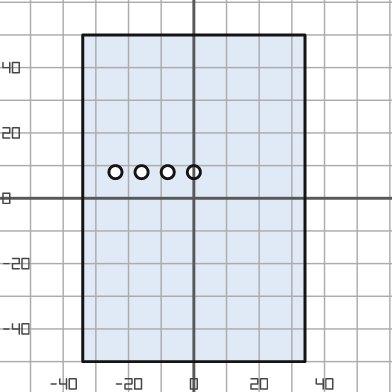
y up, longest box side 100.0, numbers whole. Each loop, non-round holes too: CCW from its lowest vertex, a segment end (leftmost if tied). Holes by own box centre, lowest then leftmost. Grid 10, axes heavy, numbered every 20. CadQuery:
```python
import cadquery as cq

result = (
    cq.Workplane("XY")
    .moveTo(-34.0, -50.0)
    .lineTo(34.0, -50.0)
    .lineTo(34.0, 50.0)
    .lineTo(-34.0, 50.0)
    .close()
    .moveTo(-24.0, 8.0)
    .circle(2.0)
    .moveTo(-16.0, 8.0)
    .circle(2.0)
    .moveTo(-8.0, 8.0)
    .circle(2.0)
    .moveTo(0.0, 8.0)
    .circle(2.0)
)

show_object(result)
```